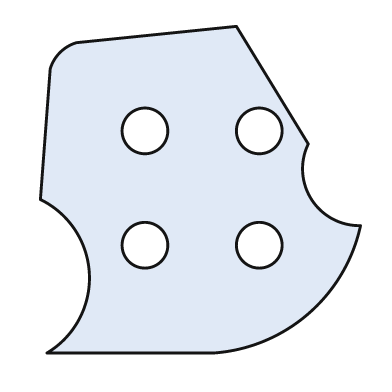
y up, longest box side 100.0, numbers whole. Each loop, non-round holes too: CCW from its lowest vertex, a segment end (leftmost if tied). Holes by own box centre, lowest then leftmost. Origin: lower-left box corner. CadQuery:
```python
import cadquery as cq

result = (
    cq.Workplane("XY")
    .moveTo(2.0, 0.0)
    .lineTo(53.0, 0.0)
    .threePointArc((82.0, 12.0), (98.0, 39.0))
    .threePointArc((83.0, 47.0), (82.0, 64.0))
    .lineTo(60.0, 100.0)
    .lineTo(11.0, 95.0)
    .threePointArc((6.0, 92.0), (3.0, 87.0))
    .lineTo(0.0, 47.0)
    .threePointArc((15.0, 24.0), (2.0, 0.0))
    .close()
    .moveTo(32.0, 33.0)
    .circle(7.0)
    .moveTo(67.0, 33.0)
    .circle(7.0)
    .moveTo(32.0, 68.0)
    .circle(7.0)
    .moveTo(67.0, 68.0)
    .circle(7.0)
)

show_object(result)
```